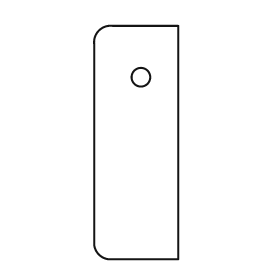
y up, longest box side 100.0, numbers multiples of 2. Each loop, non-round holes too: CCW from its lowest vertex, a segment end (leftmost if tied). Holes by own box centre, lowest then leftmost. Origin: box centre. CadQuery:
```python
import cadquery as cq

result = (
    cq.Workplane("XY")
    .moveTo(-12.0, -50.0)
    .lineTo(18.0, -50.0)
    .lineTo(18.0, 50.0)
    .lineTo(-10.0, 50.0)
    .threePointArc((-16.0, 48.0), (-18.0, 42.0))
    .lineTo(-18.0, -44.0)
    .threePointArc((-16.0, -48.0), (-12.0, -50.0))
    .close()
    .moveTo(2.0, 28.0)
    .circle(4.0)
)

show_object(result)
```